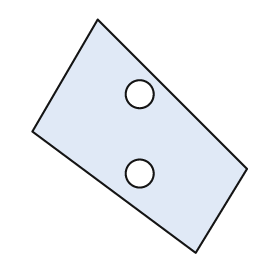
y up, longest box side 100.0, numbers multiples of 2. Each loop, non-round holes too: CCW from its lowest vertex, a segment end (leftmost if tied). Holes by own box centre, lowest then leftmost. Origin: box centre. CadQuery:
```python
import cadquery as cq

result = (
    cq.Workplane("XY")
    .moveTo(24.0, -50.0)
    .lineTo(46.0, -14.0)
    .lineTo(-18.0, 50.0)
    .lineTo(-46.0, 2.0)
    .close()
    .moveTo(0.0, -16.0)
    .circle(6.0)
    .moveTo(0.0, 18.0)
    .circle(6.0)
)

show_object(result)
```